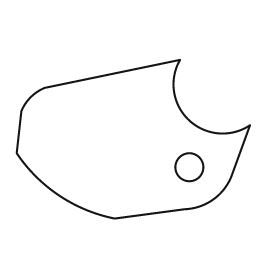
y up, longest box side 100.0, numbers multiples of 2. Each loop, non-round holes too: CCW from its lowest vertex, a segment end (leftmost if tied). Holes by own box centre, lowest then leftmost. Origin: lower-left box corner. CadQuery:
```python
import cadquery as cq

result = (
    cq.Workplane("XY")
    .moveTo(42.0, 0.0)
    .lineTo(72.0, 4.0)
    .threePointArc((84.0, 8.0), (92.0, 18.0))
    .lineTo(100.0, 40.0)
    .threePointArc((74.0, 42.0), (70.0, 68.0))
    .lineTo(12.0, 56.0)
    .threePointArc((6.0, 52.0), (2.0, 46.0))
    .lineTo(0.0, 28.0)
    .threePointArc((18.0, 10.0), (42.0, 0.0))
    .close()
    .moveTo(74.0, 22.0)
    .circle(6.0)
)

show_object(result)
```